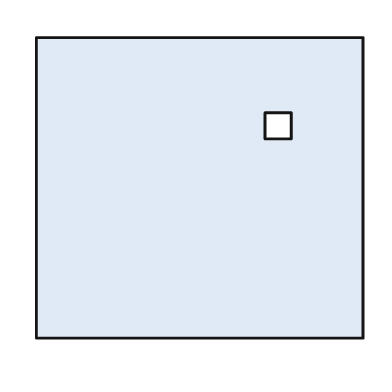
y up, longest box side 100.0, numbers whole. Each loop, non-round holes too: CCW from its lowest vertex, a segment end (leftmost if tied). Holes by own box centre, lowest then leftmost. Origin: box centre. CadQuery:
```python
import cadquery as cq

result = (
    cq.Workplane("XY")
    .moveTo(-50.0, -46.0)
    .lineTo(50.0, -46.0)
    .lineTo(50.0, 46.0)
    .lineTo(-50.0, 46.0)
    .close()
    .moveTo(20.0, 15.0)
    .lineTo(28.0, 15.0)
    .lineTo(28.0, 23.0)
    .lineTo(20.0, 23.0)
    .close()
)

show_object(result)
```